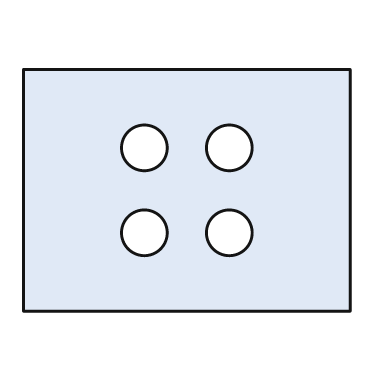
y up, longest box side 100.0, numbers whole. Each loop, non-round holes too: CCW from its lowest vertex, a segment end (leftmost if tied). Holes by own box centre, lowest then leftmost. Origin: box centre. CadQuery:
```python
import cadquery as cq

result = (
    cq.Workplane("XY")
    .moveTo(-50.0, -37.0)
    .lineTo(50.0, -37.0)
    .lineTo(50.0, 37.0)
    .lineTo(-50.0, 37.0)
    .close()
    .moveTo(-13.0, -13.0)
    .circle(7.0)
    .moveTo(13.0, -13.0)
    .circle(7.0)
    .moveTo(-13.0, 13.0)
    .circle(7.0)
    .moveTo(13.0, 13.0)
    .circle(7.0)
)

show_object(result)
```